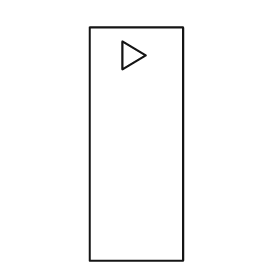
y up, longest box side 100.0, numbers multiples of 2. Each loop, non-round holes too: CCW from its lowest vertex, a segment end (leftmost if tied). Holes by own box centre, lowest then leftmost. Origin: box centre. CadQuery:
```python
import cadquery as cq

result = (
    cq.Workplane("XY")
    .moveTo(-20.0, -50.0)
    .lineTo(20.0, -50.0)
    .lineTo(20.0, 50.0)
    .lineTo(-20.0, 50.0)
    .close()
    .moveTo(-6.0, 32.0)
    .lineTo(4.0, 38.0)
    .lineTo(-6.0, 44.0)
    .close()
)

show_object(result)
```